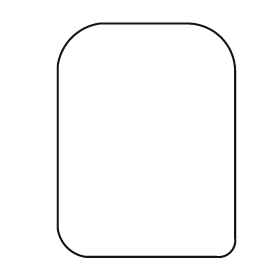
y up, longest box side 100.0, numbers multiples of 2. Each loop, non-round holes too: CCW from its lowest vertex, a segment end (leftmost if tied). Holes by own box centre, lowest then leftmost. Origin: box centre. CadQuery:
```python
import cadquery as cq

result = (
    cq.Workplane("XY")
    .moveTo(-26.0, -50.0)
    .lineTo(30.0, -50.0)
    .threePointArc((36.0, -48.0), (38.0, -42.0))
    .lineTo(38.0, 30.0)
    .threePointArc((32.0, 44.0), (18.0, 50.0))
    .lineTo(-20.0, 50.0)
    .threePointArc((-32.0, 44.0), (-38.0, 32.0))
    .lineTo(-38.0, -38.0)
    .threePointArc((-34.0, -46.0), (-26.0, -50.0))
    .close()
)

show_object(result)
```